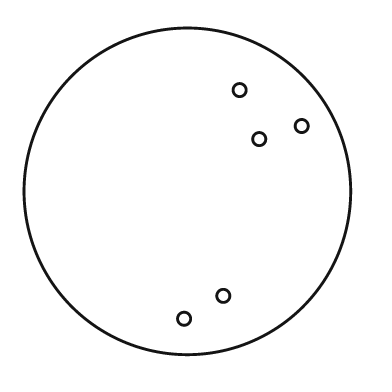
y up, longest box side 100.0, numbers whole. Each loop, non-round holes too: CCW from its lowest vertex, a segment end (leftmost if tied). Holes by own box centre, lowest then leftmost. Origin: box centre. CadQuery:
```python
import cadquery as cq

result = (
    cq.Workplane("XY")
    .moveTo(0.0, 0.0)
    .circle(50.0)
    .moveTo(-1.0, -39.0)
    .circle(2.0)
    .moveTo(11.0, -32.0)
    .circle(2.0)
    .moveTo(22.0, 16.0)
    .circle(2.0)
    .moveTo(35.0, 20.0)
    .circle(2.0)
    .moveTo(16.0, 31.0)
    .circle(2.0)
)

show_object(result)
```